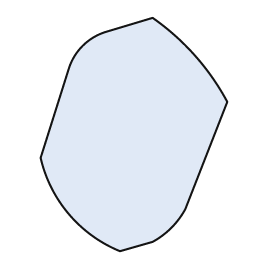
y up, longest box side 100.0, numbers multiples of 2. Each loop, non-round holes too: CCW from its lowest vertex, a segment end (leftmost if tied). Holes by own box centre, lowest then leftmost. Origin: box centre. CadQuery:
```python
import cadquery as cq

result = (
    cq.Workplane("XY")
    .moveTo(-6.0, -50.0)
    .lineTo(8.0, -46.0)
    .threePointArc((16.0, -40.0), (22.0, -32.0))
    .lineTo(40.0, 14.0)
    .threePointArc((26.0, 34.0), (8.0, 50.0))
    .lineTo(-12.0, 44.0)
    .threePointArc((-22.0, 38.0), (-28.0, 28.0))
    .lineTo(-40.0, -10.0)
    .threePointArc((-28.0, -34.0), (-6.0, -50.0))
    .close()
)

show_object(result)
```